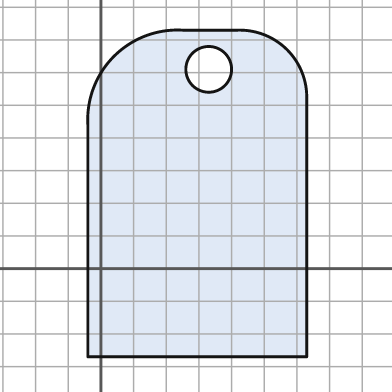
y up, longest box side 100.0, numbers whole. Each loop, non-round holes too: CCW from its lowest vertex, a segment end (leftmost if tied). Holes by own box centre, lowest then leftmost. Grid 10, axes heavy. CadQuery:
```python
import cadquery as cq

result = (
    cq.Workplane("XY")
    .moveTo(-4.0, -27.0)
    .lineTo(63.0, -27.0)
    .lineTo(63.0, 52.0)
    .threePointArc((57.0, 67.0), (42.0, 73.0))
    .lineTo(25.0, 73.0)
    .threePointArc((4.0, 65.0), (-4.0, 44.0))
    .close()
    .moveTo(33.0, 61.0)
    .circle(7.0)
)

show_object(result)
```